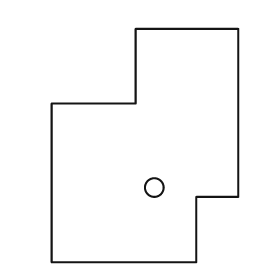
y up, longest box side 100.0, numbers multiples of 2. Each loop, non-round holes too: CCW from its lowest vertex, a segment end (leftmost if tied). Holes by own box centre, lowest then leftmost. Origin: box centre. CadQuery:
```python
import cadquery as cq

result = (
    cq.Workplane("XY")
    .moveTo(-40.0, -50.0)
    .lineTo(22.0, -50.0)
    .lineTo(22.0, -22.0)
    .lineTo(40.0, -22.0)
    .lineTo(40.0, 50.0)
    .lineTo(-4.0, 50.0)
    .lineTo(-4.0, 18.0)
    .lineTo(-40.0, 18.0)
    .close()
    .moveTo(4.0, -18.0)
    .circle(4.0)
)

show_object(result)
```